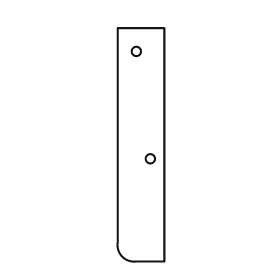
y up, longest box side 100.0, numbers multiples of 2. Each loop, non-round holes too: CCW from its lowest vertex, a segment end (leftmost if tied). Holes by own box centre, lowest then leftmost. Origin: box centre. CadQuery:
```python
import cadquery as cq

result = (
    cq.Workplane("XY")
    .moveTo(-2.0, -50.0)
    .lineTo(10.0, -50.0)
    .lineTo(10.0, 50.0)
    .lineTo(-10.0, 50.0)
    .lineTo(-10.0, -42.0)
    .threePointArc((-8.0, -48.0), (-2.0, -50.0))
    .close()
    .moveTo(4.0, -6.0)
    .circle(2.0)
    .moveTo(-2.0, 40.0)
    .circle(2.0)
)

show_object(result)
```